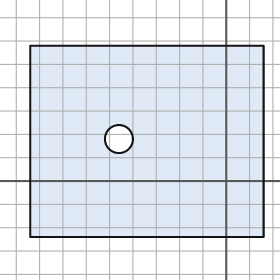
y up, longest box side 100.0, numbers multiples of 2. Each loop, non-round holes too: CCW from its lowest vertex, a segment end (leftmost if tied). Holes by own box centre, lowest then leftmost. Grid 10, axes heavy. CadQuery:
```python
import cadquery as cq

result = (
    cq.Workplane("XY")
    .moveTo(-84.0, -24.0)
    .lineTo(16.0, -24.0)
    .lineTo(16.0, 58.0)
    .lineTo(-84.0, 58.0)
    .close()
    .moveTo(-46.0, 18.0)
    .circle(6.0)
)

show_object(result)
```